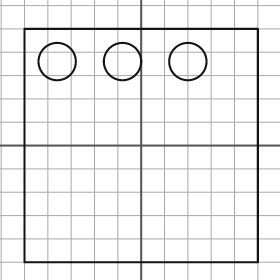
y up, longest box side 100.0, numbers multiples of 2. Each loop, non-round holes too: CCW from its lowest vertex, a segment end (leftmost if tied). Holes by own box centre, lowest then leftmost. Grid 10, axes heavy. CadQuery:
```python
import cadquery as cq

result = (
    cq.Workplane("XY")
    .moveTo(-50.0, -50.0)
    .lineTo(50.0, -50.0)
    .lineTo(50.0, 50.0)
    .lineTo(-50.0, 50.0)
    .close()
    .moveTo(-36.0, 36.0)
    .circle(8.0)
    .moveTo(-8.0, 36.0)
    .circle(8.0)
    .moveTo(20.0, 36.0)
    .circle(8.0)
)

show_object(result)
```